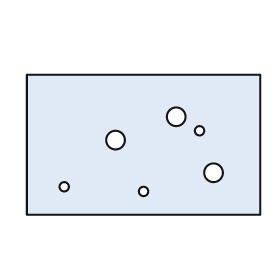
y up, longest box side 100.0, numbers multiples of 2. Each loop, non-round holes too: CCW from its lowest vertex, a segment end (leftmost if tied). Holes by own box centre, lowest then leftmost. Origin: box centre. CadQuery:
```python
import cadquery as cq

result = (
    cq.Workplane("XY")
    .moveTo(-50.0, -30.0)
    .lineTo(50.0, -30.0)
    .lineTo(50.0, 30.0)
    .lineTo(-50.0, 30.0)
    .close()
    .moveTo(0.0, -20.0)
    .circle(2.0)
    .moveTo(-34.0, -18.0)
    .circle(2.0)
    .moveTo(30.0, -12.0)
    .circle(4.0)
    .moveTo(-12.0, 2.0)
    .circle(4.0)
    .moveTo(24.0, 6.0)
    .circle(2.0)
    .moveTo(14.0, 12.0)
    .circle(4.0)
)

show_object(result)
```